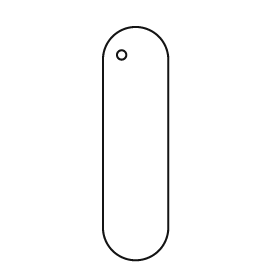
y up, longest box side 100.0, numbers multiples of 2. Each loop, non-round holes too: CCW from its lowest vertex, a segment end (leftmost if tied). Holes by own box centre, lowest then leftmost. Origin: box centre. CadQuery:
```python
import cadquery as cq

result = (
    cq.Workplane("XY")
    .moveTo(-14.0, -36.0)
    .threePointArc((0.0, -50.0), (14.0, -36.0))
    .lineTo(14.0, 36.0)
    .threePointArc((0.0, 50.0), (-14.0, 36.0))
    .close()
    .moveTo(-6.0, 38.0)
    .circle(2.0)
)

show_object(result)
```